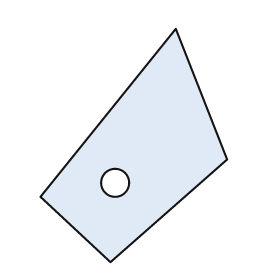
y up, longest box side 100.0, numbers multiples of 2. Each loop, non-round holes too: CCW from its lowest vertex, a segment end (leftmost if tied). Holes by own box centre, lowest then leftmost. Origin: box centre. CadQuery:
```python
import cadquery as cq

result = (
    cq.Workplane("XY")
    .moveTo(-10.0, -50.0)
    .lineTo(40.0, -6.0)
    .lineTo(18.0, 50.0)
    .lineTo(-40.0, -22.0)
    .close()
    .moveTo(-8.0, -16.0)
    .circle(6.0)
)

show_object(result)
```